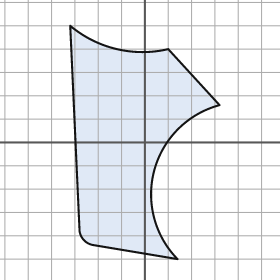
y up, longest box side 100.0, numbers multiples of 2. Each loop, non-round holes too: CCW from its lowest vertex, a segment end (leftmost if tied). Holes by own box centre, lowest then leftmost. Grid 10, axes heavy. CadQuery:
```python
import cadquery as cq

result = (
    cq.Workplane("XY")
    .moveTo(14.0, -50.0)
    .threePointArc((4.0, -12.0), (32.0, 16.0))
    .lineTo(10.0, 40.0)
    .threePointArc((-12.0, 40.0), (-32.0, 50.0))
    .lineTo(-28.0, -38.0)
    .threePointArc((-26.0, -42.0), (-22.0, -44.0))
    .close()
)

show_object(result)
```